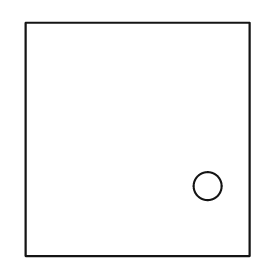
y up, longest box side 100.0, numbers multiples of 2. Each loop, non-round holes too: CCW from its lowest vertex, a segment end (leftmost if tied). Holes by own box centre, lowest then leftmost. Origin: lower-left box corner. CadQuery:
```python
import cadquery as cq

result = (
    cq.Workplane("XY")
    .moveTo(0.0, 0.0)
    .lineTo(96.0, 0.0)
    .lineTo(96.0, 100.0)
    .lineTo(0.0, 100.0)
    .close()
    .moveTo(78.0, 30.0)
    .circle(6.0)
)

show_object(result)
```